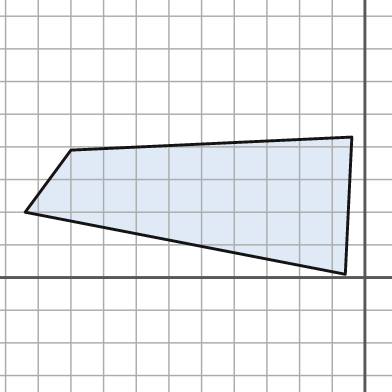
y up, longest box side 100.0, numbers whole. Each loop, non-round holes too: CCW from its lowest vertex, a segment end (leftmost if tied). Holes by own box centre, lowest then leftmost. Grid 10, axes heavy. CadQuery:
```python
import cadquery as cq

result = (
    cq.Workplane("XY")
    .moveTo(-6.0, 1.0)
    .lineTo(-4.0, 43.0)
    .lineTo(-90.0, 39.0)
    .lineTo(-104.0, 20.0)
    .close()
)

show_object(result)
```